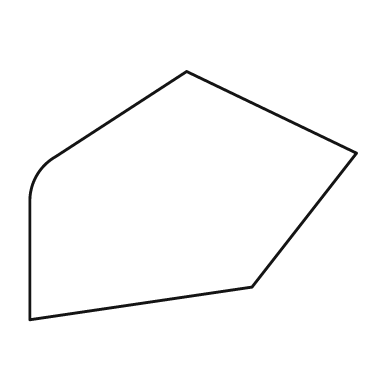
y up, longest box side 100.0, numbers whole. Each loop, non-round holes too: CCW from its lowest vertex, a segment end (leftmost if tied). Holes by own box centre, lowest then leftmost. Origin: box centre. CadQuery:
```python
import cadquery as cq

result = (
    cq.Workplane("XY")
    .moveTo(-50.0, -38.0)
    .lineTo(18.0, -28.0)
    .lineTo(50.0, 13.0)
    .lineTo(-2.0, 38.0)
    .lineTo(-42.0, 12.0)
    .threePointArc((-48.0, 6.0), (-50.0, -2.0))
    .close()
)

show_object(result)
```